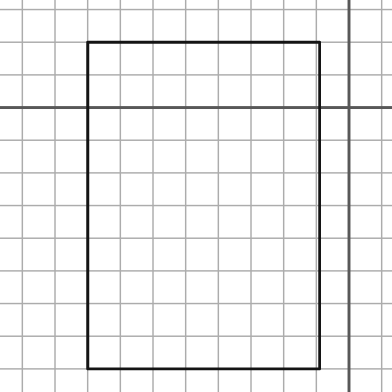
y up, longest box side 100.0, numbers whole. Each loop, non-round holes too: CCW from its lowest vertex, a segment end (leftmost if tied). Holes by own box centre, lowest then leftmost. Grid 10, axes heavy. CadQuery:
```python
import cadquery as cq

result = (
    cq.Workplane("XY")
    .moveTo(-80.0, -80.0)
    .lineTo(-9.0, -80.0)
    .lineTo(-9.0, 20.0)
    .lineTo(-80.0, 20.0)
    .close()
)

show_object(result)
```